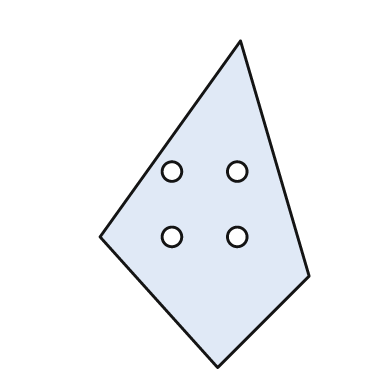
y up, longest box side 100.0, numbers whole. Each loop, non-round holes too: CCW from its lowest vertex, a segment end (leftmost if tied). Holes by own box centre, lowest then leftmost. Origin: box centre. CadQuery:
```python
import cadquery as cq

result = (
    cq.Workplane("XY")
    .moveTo(4.0, -50.0)
    .lineTo(32.0, -22.0)
    .lineTo(11.0, 50.0)
    .lineTo(-32.0, -10.0)
    .close()
    .moveTo(-10.0, -10.0)
    .circle(3.0)
    .moveTo(10.0, -10.0)
    .circle(3.0)
    .moveTo(-10.0, 10.0)
    .circle(3.0)
    .moveTo(10.0, 10.0)
    .circle(3.0)
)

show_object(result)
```